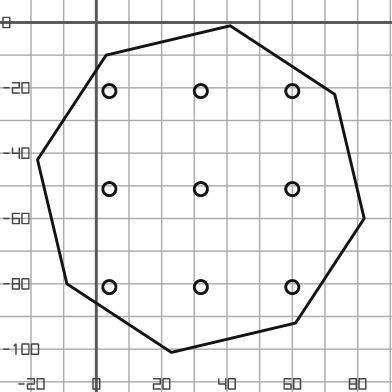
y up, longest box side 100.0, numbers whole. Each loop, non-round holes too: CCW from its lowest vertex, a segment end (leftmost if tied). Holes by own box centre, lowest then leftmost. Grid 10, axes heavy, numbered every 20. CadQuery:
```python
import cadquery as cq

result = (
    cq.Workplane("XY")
    .moveTo(23.0, -101.0)
    .lineTo(61.0, -92.0)
    .lineTo(82.0, -60.0)
    .lineTo(73.0, -22.0)
    .lineTo(41.0, -1.0)
    .lineTo(3.0, -10.0)
    .lineTo(-18.0, -42.0)
    .lineTo(-9.0, -80.0)
    .close()
    .moveTo(4.0, -81.0)
    .circle(2.0)
    .moveTo(32.0, -81.0)
    .circle(2.0)
    .moveTo(60.0, -81.0)
    .circle(2.0)
    .moveTo(4.0, -51.0)
    .circle(2.0)
    .moveTo(32.0, -51.0)
    .circle(2.0)
    .moveTo(60.0, -51.0)
    .circle(2.0)
    .moveTo(4.0, -21.0)
    .circle(2.0)
    .moveTo(32.0, -21.0)
    .circle(2.0)
    .moveTo(60.0, -21.0)
    .circle(2.0)
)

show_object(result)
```